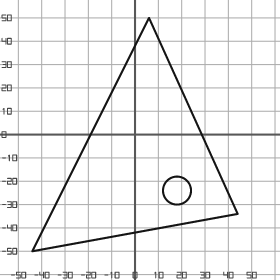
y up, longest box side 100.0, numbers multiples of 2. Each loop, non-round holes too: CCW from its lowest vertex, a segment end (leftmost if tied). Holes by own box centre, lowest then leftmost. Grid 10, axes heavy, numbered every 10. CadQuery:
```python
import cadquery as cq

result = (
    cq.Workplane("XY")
    .moveTo(-44.0, -50.0)
    .lineTo(44.0, -34.0)
    .lineTo(6.0, 50.0)
    .close()
    .moveTo(18.0, -24.0)
    .circle(6.0)
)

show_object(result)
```